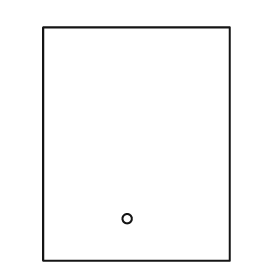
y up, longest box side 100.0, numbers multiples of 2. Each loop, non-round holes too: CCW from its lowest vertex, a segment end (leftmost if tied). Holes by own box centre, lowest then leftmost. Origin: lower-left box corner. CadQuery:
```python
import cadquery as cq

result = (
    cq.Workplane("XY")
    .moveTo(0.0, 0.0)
    .lineTo(80.0, 0.0)
    .lineTo(80.0, 100.0)
    .lineTo(0.0, 100.0)
    .close()
    .moveTo(36.0, 18.0)
    .circle(2.0)
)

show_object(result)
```